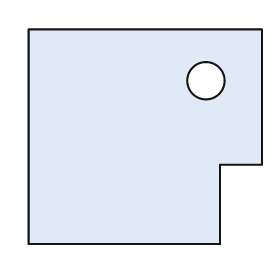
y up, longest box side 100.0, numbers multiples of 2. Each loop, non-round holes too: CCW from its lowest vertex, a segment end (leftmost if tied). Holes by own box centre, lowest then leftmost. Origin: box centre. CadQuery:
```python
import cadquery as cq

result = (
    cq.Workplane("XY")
    .moveTo(-50.0, -46.0)
    .lineTo(32.0, -46.0)
    .lineTo(32.0, -12.0)
    .lineTo(50.0, -12.0)
    .lineTo(50.0, 46.0)
    .lineTo(-50.0, 46.0)
    .close()
    .moveTo(26.0, 24.0)
    .circle(8.0)
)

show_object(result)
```